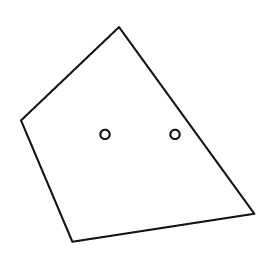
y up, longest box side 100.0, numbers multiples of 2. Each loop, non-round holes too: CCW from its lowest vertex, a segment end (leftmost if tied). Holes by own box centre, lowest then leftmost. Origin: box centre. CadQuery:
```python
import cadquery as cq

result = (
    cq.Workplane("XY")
    .moveTo(-28.0, -46.0)
    .lineTo(50.0, -34.0)
    .lineTo(-8.0, 46.0)
    .lineTo(-50.0, 6.0)
    .close()
    .moveTo(-14.0, 0.0)
    .circle(2.0)
    .moveTo(16.0, 0.0)
    .circle(2.0)
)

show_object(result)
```